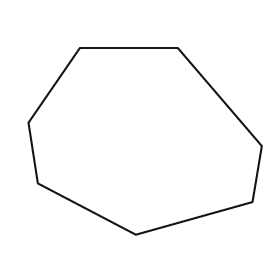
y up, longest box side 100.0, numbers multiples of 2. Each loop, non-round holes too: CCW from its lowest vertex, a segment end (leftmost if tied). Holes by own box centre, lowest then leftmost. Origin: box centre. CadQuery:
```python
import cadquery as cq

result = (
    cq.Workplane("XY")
    .moveTo(-4.0, -40.0)
    .lineTo(46.0, -26.0)
    .lineTo(50.0, -2.0)
    .lineTo(14.0, 40.0)
    .lineTo(-28.0, 40.0)
    .lineTo(-50.0, 8.0)
    .lineTo(-46.0, -18.0)
    .close()
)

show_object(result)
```